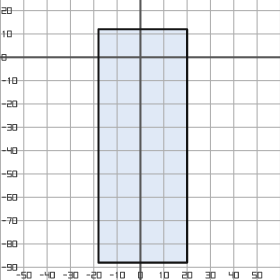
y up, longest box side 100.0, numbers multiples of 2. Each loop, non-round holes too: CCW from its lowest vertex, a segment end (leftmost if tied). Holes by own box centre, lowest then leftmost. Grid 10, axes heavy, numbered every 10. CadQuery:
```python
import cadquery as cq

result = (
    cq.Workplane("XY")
    .moveTo(-18.0, -88.0)
    .lineTo(20.0, -88.0)
    .lineTo(20.0, 12.0)
    .lineTo(-18.0, 12.0)
    .close()
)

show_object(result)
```